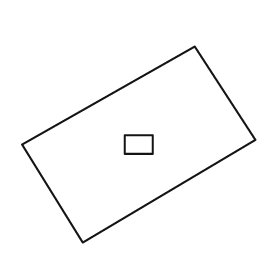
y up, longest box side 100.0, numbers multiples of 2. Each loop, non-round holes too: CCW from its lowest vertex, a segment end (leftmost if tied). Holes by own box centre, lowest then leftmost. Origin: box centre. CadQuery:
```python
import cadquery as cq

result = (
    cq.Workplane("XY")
    .moveTo(-24.0, -42.0)
    .lineTo(50.0, 2.0)
    .lineTo(24.0, 42.0)
    .lineTo(-50.0, 0.0)
    .close()
    .moveTo(-6.0, -4.0)
    .lineTo(6.0, -4.0)
    .lineTo(6.0, 4.0)
    .lineTo(-6.0, 4.0)
    .close()
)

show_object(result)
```